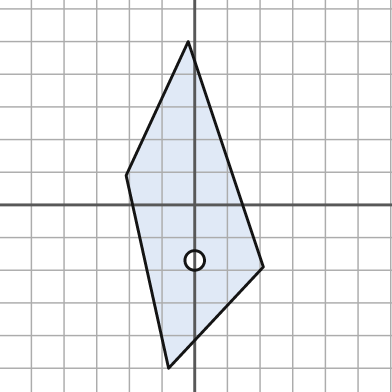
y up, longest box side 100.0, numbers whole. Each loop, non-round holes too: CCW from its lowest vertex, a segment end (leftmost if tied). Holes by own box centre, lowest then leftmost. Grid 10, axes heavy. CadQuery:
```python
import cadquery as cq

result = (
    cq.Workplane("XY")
    .moveTo(-8.0, -50.0)
    .lineTo(21.0, -19.0)
    .lineTo(-2.0, 50.0)
    .lineTo(-21.0, 9.0)
    .close()
    .moveTo(0.0, -17.0)
    .circle(3.0)
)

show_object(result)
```